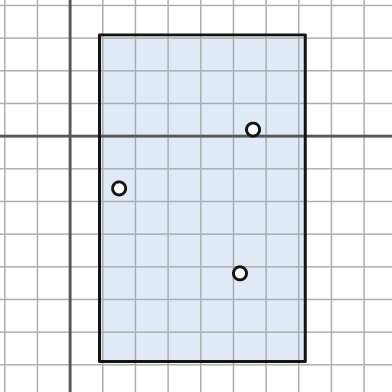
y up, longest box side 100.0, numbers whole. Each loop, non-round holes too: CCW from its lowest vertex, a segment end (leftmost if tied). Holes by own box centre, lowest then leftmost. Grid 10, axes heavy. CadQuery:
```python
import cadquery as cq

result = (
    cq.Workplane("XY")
    .moveTo(9.0, -69.0)
    .lineTo(72.0, -69.0)
    .lineTo(72.0, 31.0)
    .lineTo(9.0, 31.0)
    .close()
    .moveTo(52.0, -42.0)
    .circle(2.0)
    .moveTo(15.0, -16.0)
    .circle(2.0)
    .moveTo(56.0, 2.0)
    .circle(2.0)
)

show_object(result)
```